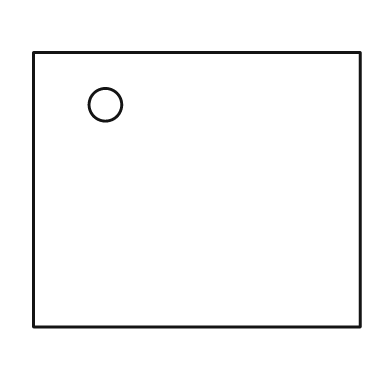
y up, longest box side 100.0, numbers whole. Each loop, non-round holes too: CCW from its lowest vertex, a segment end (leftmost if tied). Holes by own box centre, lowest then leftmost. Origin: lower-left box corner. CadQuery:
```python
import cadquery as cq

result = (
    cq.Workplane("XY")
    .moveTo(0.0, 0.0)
    .lineTo(100.0, 0.0)
    .lineTo(100.0, 84.0)
    .lineTo(0.0, 84.0)
    .close()
    .moveTo(22.0, 68.0)
    .circle(5.0)
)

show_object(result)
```